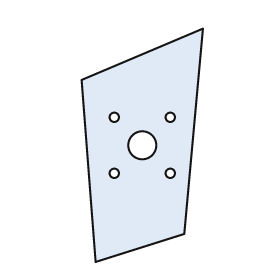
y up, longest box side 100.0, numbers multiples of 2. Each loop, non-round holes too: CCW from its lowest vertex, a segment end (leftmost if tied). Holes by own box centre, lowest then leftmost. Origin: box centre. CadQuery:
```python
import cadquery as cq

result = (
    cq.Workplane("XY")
    .moveTo(-20.0, -50.0)
    .lineTo(18.0, -38.0)
    .lineTo(26.0, 50.0)
    .lineTo(-26.0, 28.0)
    .close()
    .moveTo(-12.0, -12.0)
    .circle(2.0)
    .moveTo(12.0, -12.0)
    .circle(2.0)
    .moveTo(0.0, 0.0)
    .circle(6.0)
    .moveTo(-12.0, 12.0)
    .circle(2.0)
    .moveTo(12.0, 12.0)
    .circle(2.0)
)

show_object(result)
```